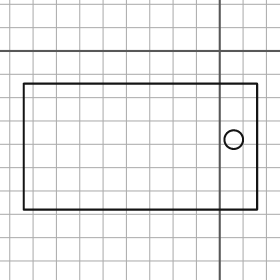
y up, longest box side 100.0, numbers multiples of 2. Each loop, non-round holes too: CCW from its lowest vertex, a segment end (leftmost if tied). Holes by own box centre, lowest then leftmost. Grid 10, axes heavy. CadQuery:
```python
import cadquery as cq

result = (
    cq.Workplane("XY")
    .moveTo(-84.0, -68.0)
    .lineTo(16.0, -68.0)
    .lineTo(16.0, -14.0)
    .lineTo(-84.0, -14.0)
    .close()
    .moveTo(6.0, -38.0)
    .circle(4.0)
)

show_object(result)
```